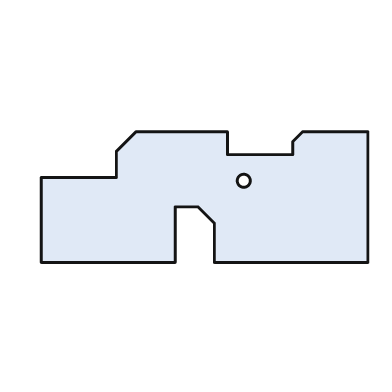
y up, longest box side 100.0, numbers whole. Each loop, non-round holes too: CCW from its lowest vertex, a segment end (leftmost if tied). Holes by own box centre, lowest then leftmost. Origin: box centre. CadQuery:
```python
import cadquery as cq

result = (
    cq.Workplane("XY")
    .moveTo(-50.0, -20.0)
    .lineTo(-9.0, -20.0)
    .lineTo(-9.0, -3.0)
    .lineTo(-2.0, -3.0)
    .lineTo(3.0, -8.0)
    .lineTo(3.0, -20.0)
    .lineTo(50.0, -20.0)
    .lineTo(50.0, 20.0)
    .lineTo(30.0, 20.0)
    .lineTo(27.0, 17.0)
    .lineTo(27.0, 13.0)
    .lineTo(7.0, 13.0)
    .lineTo(7.0, 20.0)
    .lineTo(-21.0, 20.0)
    .lineTo(-27.0, 14.0)
    .lineTo(-27.0, 6.0)
    .lineTo(-50.0, 6.0)
    .close()
    .moveTo(12.0, 5.0)
    .circle(2.0)
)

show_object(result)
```